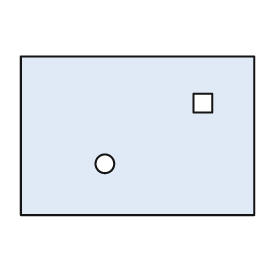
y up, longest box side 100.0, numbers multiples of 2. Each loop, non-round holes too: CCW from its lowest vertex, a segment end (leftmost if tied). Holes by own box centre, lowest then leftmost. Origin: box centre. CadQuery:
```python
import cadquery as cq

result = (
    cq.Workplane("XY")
    .moveTo(-50.0, -34.0)
    .lineTo(50.0, -34.0)
    .lineTo(50.0, 34.0)
    .lineTo(-50.0, 34.0)
    .close()
    .moveTo(-14.0, -12.0)
    .circle(4.0)
    .moveTo(24.0, 10.0)
    .lineTo(32.0, 10.0)
    .lineTo(32.0, 18.0)
    .lineTo(24.0, 18.0)
    .close()
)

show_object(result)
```